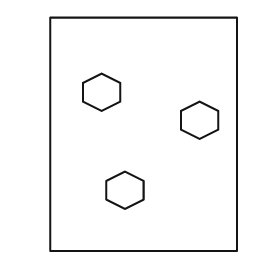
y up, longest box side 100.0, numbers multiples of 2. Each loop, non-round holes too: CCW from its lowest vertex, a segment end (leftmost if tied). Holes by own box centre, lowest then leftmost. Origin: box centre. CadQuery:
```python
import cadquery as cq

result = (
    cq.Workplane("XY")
    .moveTo(-40.0, -50.0)
    .lineTo(40.0, -50.0)
    .lineTo(40.0, 50.0)
    .lineTo(-40.0, 50.0)
    .close()
    .moveTo(-8.0, -32.0)
    .lineTo(0.0, -28.0)
    .lineTo(0.0, -20.0)
    .lineTo(-8.0, -16.0)
    .lineTo(-16.0, -20.0)
    .lineTo(-16.0, -28.0)
    .close()
    .moveTo(24.0, -2.0)
    .lineTo(32.0, 2.0)
    .lineTo(32.0, 10.0)
    .lineTo(24.0, 14.0)
    .lineTo(16.0, 10.0)
    .lineTo(16.0, 2.0)
    .close()
    .moveTo(-18.0, 10.0)
    .lineTo(-10.0, 14.0)
    .lineTo(-10.0, 22.0)
    .lineTo(-18.0, 26.0)
    .lineTo(-26.0, 22.0)
    .lineTo(-26.0, 14.0)
    .close()
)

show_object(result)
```